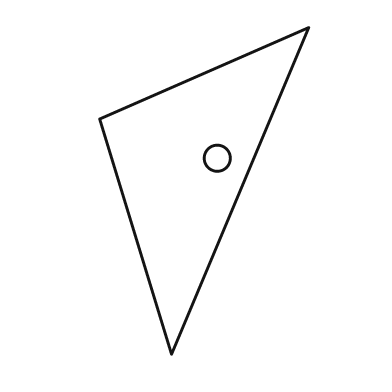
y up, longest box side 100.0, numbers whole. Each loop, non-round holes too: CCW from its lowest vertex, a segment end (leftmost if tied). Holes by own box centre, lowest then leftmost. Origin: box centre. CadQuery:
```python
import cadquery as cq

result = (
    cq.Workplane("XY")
    .moveTo(-10.0, -50.0)
    .lineTo(32.0, 50.0)
    .lineTo(-32.0, 22.0)
    .close()
    .moveTo(4.0, 10.0)
    .circle(4.0)
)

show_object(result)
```